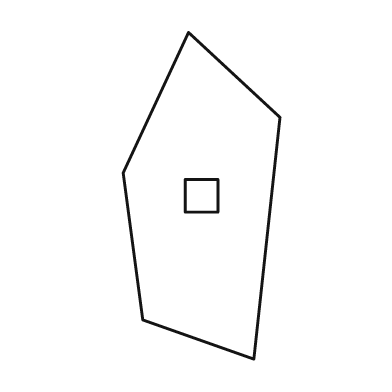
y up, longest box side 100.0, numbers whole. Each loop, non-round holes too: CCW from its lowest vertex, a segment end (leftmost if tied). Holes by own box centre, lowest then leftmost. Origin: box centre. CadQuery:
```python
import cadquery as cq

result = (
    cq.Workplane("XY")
    .moveTo(16.0, -50.0)
    .lineTo(24.0, 24.0)
    .lineTo(-4.0, 50.0)
    .lineTo(-24.0, 7.0)
    .lineTo(-18.0, -38.0)
    .close()
    .moveTo(-5.0, -5.0)
    .lineTo(5.0, -5.0)
    .lineTo(5.0, 5.0)
    .lineTo(-5.0, 5.0)
    .close()
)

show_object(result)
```